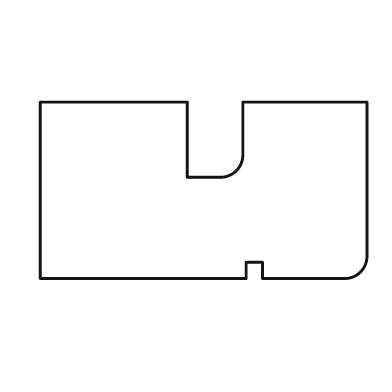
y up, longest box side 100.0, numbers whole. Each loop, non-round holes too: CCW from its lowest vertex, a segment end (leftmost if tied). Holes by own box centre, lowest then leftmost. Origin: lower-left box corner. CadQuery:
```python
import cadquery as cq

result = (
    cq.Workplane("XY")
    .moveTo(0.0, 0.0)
    .lineTo(63.0, 0.0)
    .lineTo(63.0, 5.0)
    .lineTo(68.0, 5.0)
    .lineTo(68.0, 0.0)
    .lineTo(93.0, 0.0)
    .threePointArc((98.0, 2.0), (100.0, 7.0))
    .lineTo(100.0, 54.0)
    .lineTo(62.0, 54.0)
    .lineTo(62.0, 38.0)
    .threePointArc((60.0, 33.0), (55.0, 31.0))
    .lineTo(45.0, 31.0)
    .lineTo(45.0, 54.0)
    .lineTo(0.0, 54.0)
    .close()
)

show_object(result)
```